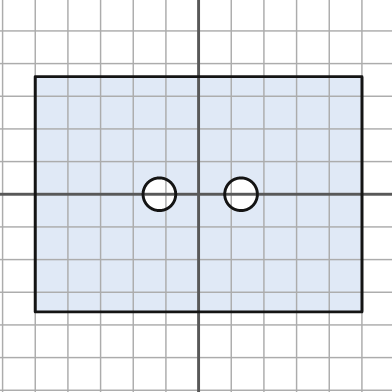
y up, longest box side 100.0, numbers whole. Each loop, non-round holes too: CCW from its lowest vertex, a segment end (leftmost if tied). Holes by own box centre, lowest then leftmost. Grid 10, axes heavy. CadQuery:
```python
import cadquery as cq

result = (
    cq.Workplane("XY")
    .moveTo(-50.0, -36.0)
    .lineTo(50.0, -36.0)
    .lineTo(50.0, 36.0)
    .lineTo(-50.0, 36.0)
    .close()
    .moveTo(-12.0, 0.0)
    .circle(5.0)
    .moveTo(13.0, 0.0)
    .circle(5.0)
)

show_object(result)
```